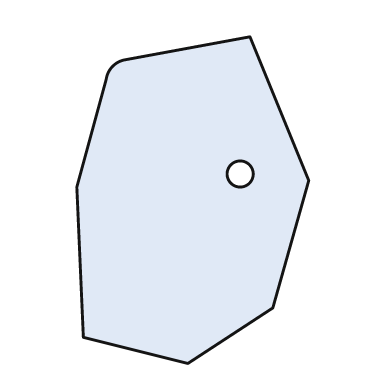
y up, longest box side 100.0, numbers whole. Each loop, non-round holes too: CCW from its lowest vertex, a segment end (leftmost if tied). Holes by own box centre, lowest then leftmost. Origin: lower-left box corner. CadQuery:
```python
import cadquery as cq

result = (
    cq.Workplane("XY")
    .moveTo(34.0, 0.0)
    .lineTo(60.0, 17.0)
    .lineTo(71.0, 56.0)
    .lineTo(53.0, 100.0)
    .lineTo(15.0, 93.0)
    .threePointArc((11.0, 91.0), (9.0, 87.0))
    .lineTo(0.0, 54.0)
    .lineTo(2.0, 8.0)
    .close()
    .moveTo(50.0, 58.0)
    .circle(4.0)
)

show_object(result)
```